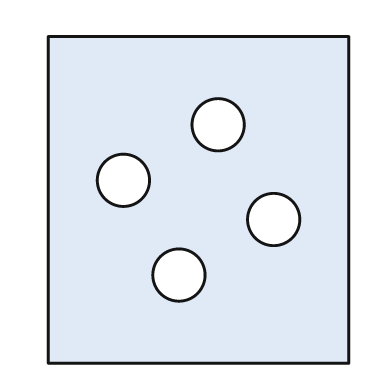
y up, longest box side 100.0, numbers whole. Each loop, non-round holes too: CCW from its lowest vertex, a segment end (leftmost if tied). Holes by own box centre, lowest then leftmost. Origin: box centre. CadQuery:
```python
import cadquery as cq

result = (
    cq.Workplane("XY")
    .moveTo(-46.0, -50.0)
    .lineTo(46.0, -50.0)
    .lineTo(46.0, 50.0)
    .lineTo(-46.0, 50.0)
    .close()
    .moveTo(-6.0, -23.0)
    .circle(8.0)
    .moveTo(23.0, -6.0)
    .circle(8.0)
    .moveTo(-23.0, 6.0)
    .circle(8.0)
    .moveTo(6.0, 23.0)
    .circle(8.0)
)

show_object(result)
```